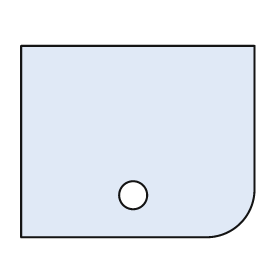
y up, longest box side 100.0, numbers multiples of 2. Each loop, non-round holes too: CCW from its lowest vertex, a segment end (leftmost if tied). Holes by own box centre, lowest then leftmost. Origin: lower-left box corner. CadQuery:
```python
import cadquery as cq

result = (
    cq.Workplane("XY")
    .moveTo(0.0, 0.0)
    .lineTo(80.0, 0.0)
    .threePointArc((94.0, 6.0), (100.0, 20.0))
    .lineTo(100.0, 82.0)
    .lineTo(0.0, 82.0)
    .close()
    .moveTo(48.0, 18.0)
    .circle(6.0)
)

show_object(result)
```